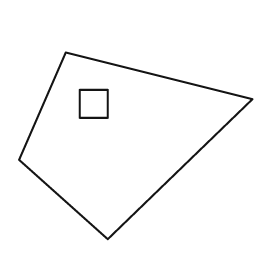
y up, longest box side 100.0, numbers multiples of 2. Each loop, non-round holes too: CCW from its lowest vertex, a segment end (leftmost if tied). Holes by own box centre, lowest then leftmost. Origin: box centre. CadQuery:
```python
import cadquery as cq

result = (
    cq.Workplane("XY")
    .moveTo(-12.0, -40.0)
    .lineTo(50.0, 20.0)
    .lineTo(-30.0, 40.0)
    .lineTo(-50.0, -6.0)
    .close()
    .moveTo(-24.0, 12.0)
    .lineTo(-12.0, 12.0)
    .lineTo(-12.0, 24.0)
    .lineTo(-24.0, 24.0)
    .close()
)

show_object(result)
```